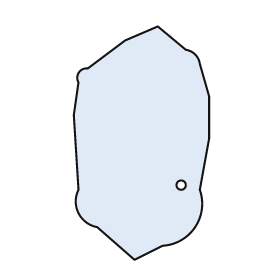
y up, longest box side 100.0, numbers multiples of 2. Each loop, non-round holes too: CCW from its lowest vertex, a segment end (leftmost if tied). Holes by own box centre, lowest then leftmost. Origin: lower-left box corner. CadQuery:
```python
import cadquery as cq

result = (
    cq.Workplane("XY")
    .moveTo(26.0, 0.0)
    .lineTo(38.0, 6.0)
    .threePointArc((52.0, 14.0), (54.0, 30.0))
    .lineTo(58.0, 52.0)
    .lineTo(58.0, 70.0)
    .lineTo(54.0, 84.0)
    .threePointArc((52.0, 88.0), (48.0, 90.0))
    .lineTo(36.0, 100.0)
    .lineTo(22.0, 94.0)
    .lineTo(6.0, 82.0)
    .threePointArc((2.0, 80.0), (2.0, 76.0))
    .lineTo(0.0, 62.0)
    .lineTo(2.0, 30.0)
    .threePointArc((2.0, 20.0), (10.0, 14.0))
    .close()
    .moveTo(46.0, 32.0)
    .circle(2.0)
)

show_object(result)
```